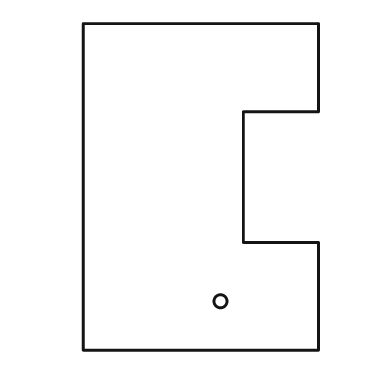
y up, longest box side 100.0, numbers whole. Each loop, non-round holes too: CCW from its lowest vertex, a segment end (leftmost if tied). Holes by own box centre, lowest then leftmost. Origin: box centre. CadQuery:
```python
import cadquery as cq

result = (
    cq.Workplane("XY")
    .moveTo(-36.0, -50.0)
    .lineTo(36.0, -50.0)
    .lineTo(36.0, -17.0)
    .lineTo(13.0, -17.0)
    .lineTo(13.0, 23.0)
    .lineTo(36.0, 23.0)
    .lineTo(36.0, 50.0)
    .lineTo(-36.0, 50.0)
    .close()
    .moveTo(6.0, -35.0)
    .circle(2.0)
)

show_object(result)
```